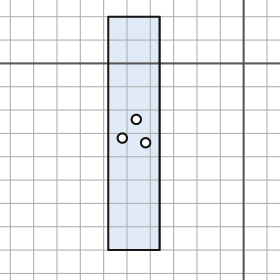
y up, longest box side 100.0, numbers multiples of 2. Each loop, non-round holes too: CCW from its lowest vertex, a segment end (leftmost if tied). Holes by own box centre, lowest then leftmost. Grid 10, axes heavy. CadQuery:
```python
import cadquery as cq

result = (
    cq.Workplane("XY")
    .moveTo(-58.0, -80.0)
    .lineTo(-36.0, -80.0)
    .lineTo(-36.0, 20.0)
    .lineTo(-58.0, 20.0)
    .close()
    .moveTo(-42.0, -34.0)
    .circle(2.0)
    .moveTo(-52.0, -32.0)
    .circle(2.0)
    .moveTo(-46.0, -24.0)
    .circle(2.0)
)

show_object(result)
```